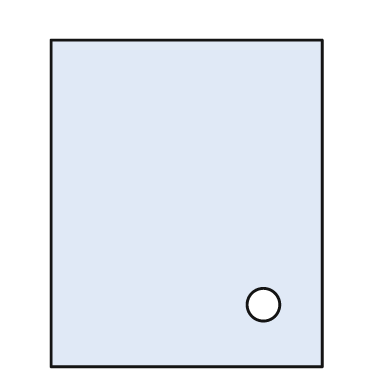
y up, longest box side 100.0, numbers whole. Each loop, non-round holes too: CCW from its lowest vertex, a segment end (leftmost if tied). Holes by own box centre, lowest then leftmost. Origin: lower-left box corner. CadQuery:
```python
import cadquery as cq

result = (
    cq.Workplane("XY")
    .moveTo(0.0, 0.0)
    .lineTo(83.0, 0.0)
    .lineTo(83.0, 100.0)
    .lineTo(0.0, 100.0)
    .close()
    .moveTo(65.0, 19.0)
    .circle(5.0)
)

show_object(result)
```